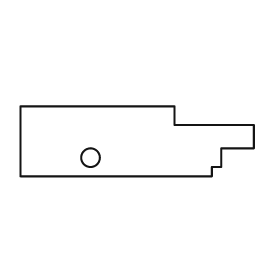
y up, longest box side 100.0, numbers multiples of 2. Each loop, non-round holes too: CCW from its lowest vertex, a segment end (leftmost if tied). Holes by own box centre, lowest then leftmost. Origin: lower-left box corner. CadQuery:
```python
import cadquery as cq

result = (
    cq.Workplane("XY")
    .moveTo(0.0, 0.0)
    .lineTo(82.0, 0.0)
    .lineTo(82.0, 4.0)
    .lineTo(86.0, 4.0)
    .lineTo(86.0, 12.0)
    .lineTo(100.0, 12.0)
    .lineTo(100.0, 22.0)
    .lineTo(66.0, 22.0)
    .lineTo(66.0, 30.0)
    .lineTo(0.0, 30.0)
    .close()
    .moveTo(30.0, 8.0)
    .circle(4.0)
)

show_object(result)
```